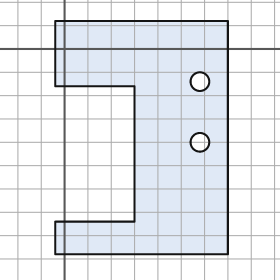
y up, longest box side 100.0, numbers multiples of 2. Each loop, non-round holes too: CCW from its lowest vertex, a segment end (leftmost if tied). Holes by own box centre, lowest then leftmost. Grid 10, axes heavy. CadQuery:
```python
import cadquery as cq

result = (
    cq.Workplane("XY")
    .moveTo(-4.0, -88.0)
    .lineTo(70.0, -88.0)
    .lineTo(70.0, 12.0)
    .lineTo(-4.0, 12.0)
    .lineTo(-4.0, -16.0)
    .lineTo(30.0, -16.0)
    .lineTo(30.0, -74.0)
    .lineTo(-4.0, -74.0)
    .close()
    .moveTo(58.0, -40.0)
    .circle(4.0)
    .moveTo(58.0, -14.0)
    .circle(4.0)
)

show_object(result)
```